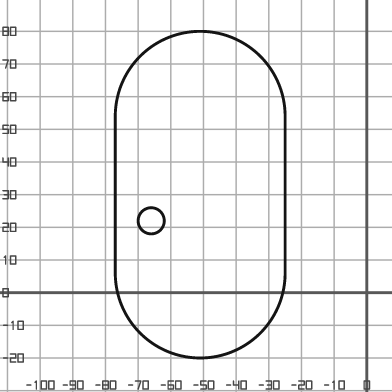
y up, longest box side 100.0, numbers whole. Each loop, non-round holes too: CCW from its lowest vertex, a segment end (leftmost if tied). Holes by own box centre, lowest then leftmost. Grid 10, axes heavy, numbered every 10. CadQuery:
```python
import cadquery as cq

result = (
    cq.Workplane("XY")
    .moveTo(-77.0, 6.0)
    .threePointArc((-51.0, -20.0), (-25.0, 6.0))
    .lineTo(-25.0, 54.0)
    .threePointArc((-51.0, 80.0), (-77.0, 54.0))
    .close()
    .moveTo(-66.0, 22.0)
    .circle(4.0)
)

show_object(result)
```